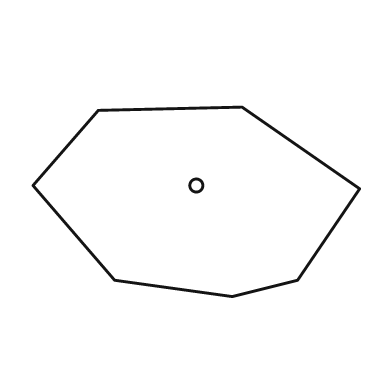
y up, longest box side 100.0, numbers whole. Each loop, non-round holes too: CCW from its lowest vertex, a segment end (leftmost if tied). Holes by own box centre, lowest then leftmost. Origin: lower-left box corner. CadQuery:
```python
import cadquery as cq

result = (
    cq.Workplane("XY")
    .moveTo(61.0, 0.0)
    .lineTo(81.0, 5.0)
    .lineTo(100.0, 33.0)
    .lineTo(64.0, 58.0)
    .lineTo(20.0, 57.0)
    .lineTo(0.0, 34.0)
    .lineTo(25.0, 5.0)
    .close()
    .moveTo(50.0, 34.0)
    .circle(2.0)
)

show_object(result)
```